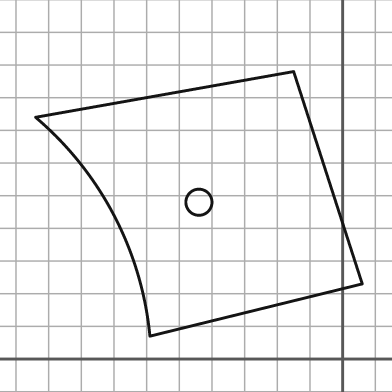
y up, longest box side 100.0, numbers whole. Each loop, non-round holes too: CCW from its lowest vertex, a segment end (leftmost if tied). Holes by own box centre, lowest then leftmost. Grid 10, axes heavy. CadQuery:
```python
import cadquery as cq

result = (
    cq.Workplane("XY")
    .moveTo(-59.0, 7.0)
    .lineTo(6.0, 23.0)
    .lineTo(-15.0, 88.0)
    .lineTo(-94.0, 74.0)
    .threePointArc((-70.0, 44.0), (-59.0, 7.0))
    .close()
    .moveTo(-44.0, 48.0)
    .circle(4.0)
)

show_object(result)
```